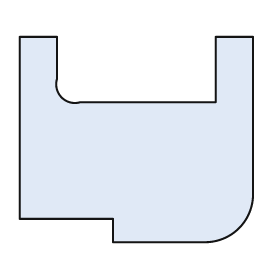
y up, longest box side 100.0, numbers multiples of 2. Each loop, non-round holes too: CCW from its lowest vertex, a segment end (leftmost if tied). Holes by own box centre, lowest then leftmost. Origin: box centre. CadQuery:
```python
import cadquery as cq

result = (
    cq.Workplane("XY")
    .moveTo(-10.0, -44.0)
    .lineTo(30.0, -44.0)
    .threePointArc((44.0, -38.0), (50.0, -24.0))
    .lineTo(50.0, 44.0)
    .lineTo(34.0, 44.0)
    .lineTo(34.0, 16.0)
    .lineTo(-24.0, 16.0)
    .threePointArc((-32.0, 18.0), (-34.0, 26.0))
    .lineTo(-34.0, 44.0)
    .lineTo(-50.0, 44.0)
    .lineTo(-50.0, -34.0)
    .lineTo(-10.0, -34.0)
    .close()
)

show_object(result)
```